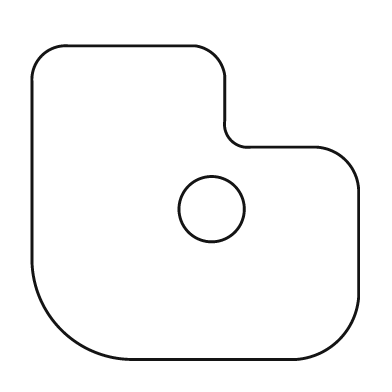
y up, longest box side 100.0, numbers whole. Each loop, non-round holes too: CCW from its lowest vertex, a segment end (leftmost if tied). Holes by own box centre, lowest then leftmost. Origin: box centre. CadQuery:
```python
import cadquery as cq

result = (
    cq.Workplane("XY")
    .moveTo(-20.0, -48.0)
    .lineTo(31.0, -48.0)
    .threePointArc((44.0, -42.0), (50.0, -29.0))
    .lineTo(50.0, 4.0)
    .threePointArc((46.0, 13.0), (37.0, 17.0))
    .lineTo(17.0, 17.0)
    .threePointArc((11.0, 19.0), (9.0, 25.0))
    .lineTo(9.0, 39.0)
    .threePointArc((6.0, 45.0), (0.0, 48.0))
    .lineTo(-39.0, 48.0)
    .threePointArc((-47.0, 45.0), (-50.0, 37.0))
    .lineTo(-50.0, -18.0)
    .threePointArc((-41.0, -39.0), (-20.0, -48.0))
    .close()
    .moveTo(5.0, -2.0)
    .circle(10.0)
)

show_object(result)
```